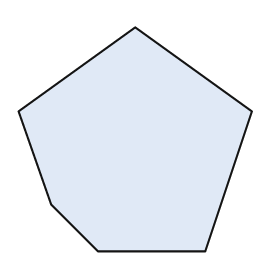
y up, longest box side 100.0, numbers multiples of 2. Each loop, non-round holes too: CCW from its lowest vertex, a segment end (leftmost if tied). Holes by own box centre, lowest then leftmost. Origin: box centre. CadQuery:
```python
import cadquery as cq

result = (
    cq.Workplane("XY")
    .moveTo(-16.0, -48.0)
    .lineTo(30.0, -48.0)
    .lineTo(50.0, 12.0)
    .lineTo(0.0, 48.0)
    .lineTo(-50.0, 12.0)
    .lineTo(-36.0, -28.0)
    .close()
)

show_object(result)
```